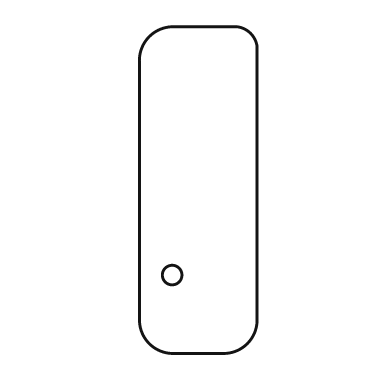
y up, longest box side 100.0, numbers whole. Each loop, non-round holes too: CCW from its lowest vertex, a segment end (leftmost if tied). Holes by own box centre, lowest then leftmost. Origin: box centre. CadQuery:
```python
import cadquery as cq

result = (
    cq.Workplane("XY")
    .moveTo(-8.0, -50.0)
    .lineTo(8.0, -50.0)
    .threePointArc((15.0, -47.0), (18.0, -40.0))
    .lineTo(18.0, 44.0)
    .threePointArc((16.0, 48.0), (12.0, 50.0))
    .lineTo(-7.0, 50.0)
    .threePointArc((-15.0, 47.0), (-18.0, 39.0))
    .lineTo(-18.0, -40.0)
    .threePointArc((-15.0, -47.0), (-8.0, -50.0))
    .close()
    .moveTo(-8.0, -26.0)
    .circle(3.0)
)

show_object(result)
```